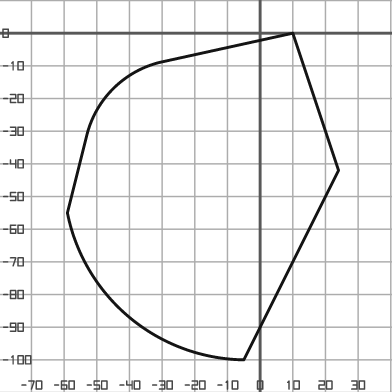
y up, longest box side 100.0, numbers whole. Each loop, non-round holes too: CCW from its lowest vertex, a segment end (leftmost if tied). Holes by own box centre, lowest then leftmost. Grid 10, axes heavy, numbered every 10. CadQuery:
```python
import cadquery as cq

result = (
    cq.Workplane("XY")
    .moveTo(-5.0, -100.0)
    .lineTo(24.0, -42.0)
    .lineTo(10.0, 0.0)
    .lineTo(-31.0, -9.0)
    .threePointArc((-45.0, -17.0), (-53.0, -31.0))
    .lineTo(-59.0, -55.0)
    .threePointArc((-40.0, -87.0), (-5.0, -100.0))
    .close()
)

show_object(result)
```